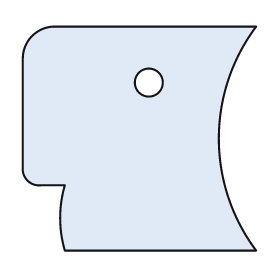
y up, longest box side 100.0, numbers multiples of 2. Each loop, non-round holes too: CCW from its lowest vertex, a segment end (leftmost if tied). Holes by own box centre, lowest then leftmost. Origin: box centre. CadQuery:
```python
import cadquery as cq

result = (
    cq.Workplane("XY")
    .moveTo(-32.0, -48.0)
    .lineTo(50.0, -48.0)
    .threePointArc((34.0, 0.0), (50.0, 48.0))
    .lineTo(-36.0, 48.0)
    .threePointArc((-46.0, 44.0), (-50.0, 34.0))
    .lineTo(-50.0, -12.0)
    .threePointArc((-48.0, -18.0), (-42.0, -20.0))
    .lineTo(-32.0, -20.0)
    .threePointArc((-34.0, -34.0), (-32.0, -48.0))
    .close()
    .moveTo(4.0, 24.0)
    .circle(6.0)
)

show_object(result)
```